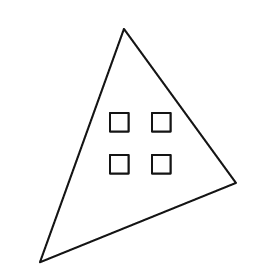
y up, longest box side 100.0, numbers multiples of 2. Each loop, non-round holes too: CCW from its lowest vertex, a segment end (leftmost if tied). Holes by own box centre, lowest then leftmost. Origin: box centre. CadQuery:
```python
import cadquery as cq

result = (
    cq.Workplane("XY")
    .moveTo(-42.0, -50.0)
    .lineTo(42.0, -16.0)
    .lineTo(-6.0, 50.0)
    .close()
    .moveTo(-12.0, -12.0)
    .lineTo(-4.0, -12.0)
    .lineTo(-4.0, -4.0)
    .lineTo(-12.0, -4.0)
    .close()
    .moveTo(6.0, -12.0)
    .lineTo(14.0, -12.0)
    .lineTo(14.0, -4.0)
    .lineTo(6.0, -4.0)
    .close()
    .moveTo(-12.0, 6.0)
    .lineTo(-4.0, 6.0)
    .lineTo(-4.0, 14.0)
    .lineTo(-12.0, 14.0)
    .close()
    .moveTo(6.0, 6.0)
    .lineTo(14.0, 6.0)
    .lineTo(14.0, 14.0)
    .lineTo(6.0, 14.0)
    .close()
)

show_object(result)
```